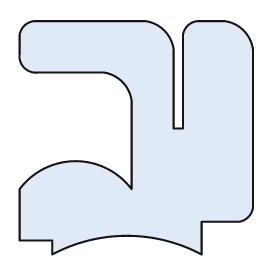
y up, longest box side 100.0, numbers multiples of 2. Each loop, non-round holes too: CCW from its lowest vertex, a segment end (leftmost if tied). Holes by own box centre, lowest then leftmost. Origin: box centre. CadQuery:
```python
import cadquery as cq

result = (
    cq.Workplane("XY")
    .moveTo(-36.0, -50.0)
    .threePointArc((-4.0, -42.0), (28.0, -50.0))
    .lineTo(28.0, -36.0)
    .lineTo(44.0, -36.0)
    .threePointArc((48.0, -34.0), (50.0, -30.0))
    .lineTo(50.0, 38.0)
    .threePointArc((46.0, 46.0), (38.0, 50.0))
    .lineTo(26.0, 50.0)
    .threePointArc((22.0, 48.0), (20.0, 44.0))
    .lineTo(20.0, 4.0)
    .lineTo(16.0, 4.0)
    .lineTo(16.0, 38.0)
    .threePointArc((12.0, 46.0), (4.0, 50.0))
    .lineTo(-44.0, 50.0)
    .threePointArc((-48.0, 48.0), (-50.0, 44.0))
    .lineTo(-50.0, 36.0)
    .threePointArc((-48.0, 30.0), (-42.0, 28.0))
    .lineTo(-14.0, 28.0)
    .threePointArc((-6.0, 24.0), (-2.0, 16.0))
    .lineTo(-2.0, -22.0)
    .threePointArc((-26.0, -10.0), (-50.0, -22.0))
    .lineTo(-50.0, -44.0)
    .lineTo(-36.0, -44.0)
    .close()
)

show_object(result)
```